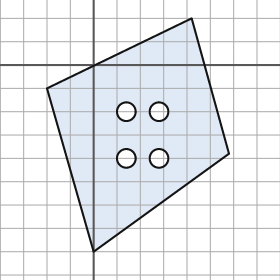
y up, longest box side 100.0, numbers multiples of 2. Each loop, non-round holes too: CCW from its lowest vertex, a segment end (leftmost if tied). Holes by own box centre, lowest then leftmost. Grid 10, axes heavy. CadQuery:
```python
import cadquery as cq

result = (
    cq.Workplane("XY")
    .moveTo(0.0, -80.0)
    .lineTo(58.0, -38.0)
    .lineTo(42.0, 20.0)
    .lineTo(-20.0, -10.0)
    .close()
    .moveTo(14.0, -40.0)
    .circle(4.0)
    .moveTo(28.0, -40.0)
    .circle(4.0)
    .moveTo(14.0, -20.0)
    .circle(4.0)
    .moveTo(28.0, -20.0)
    .circle(4.0)
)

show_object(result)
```